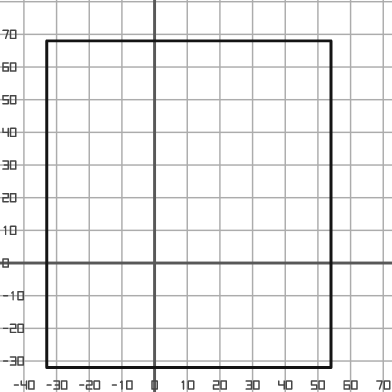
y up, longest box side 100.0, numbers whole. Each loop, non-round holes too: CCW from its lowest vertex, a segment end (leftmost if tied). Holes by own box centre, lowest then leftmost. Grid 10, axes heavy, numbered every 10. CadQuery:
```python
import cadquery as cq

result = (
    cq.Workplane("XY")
    .moveTo(-33.0, -32.0)
    .lineTo(54.0, -32.0)
    .lineTo(54.0, 68.0)
    .lineTo(-33.0, 68.0)
    .close()
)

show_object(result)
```